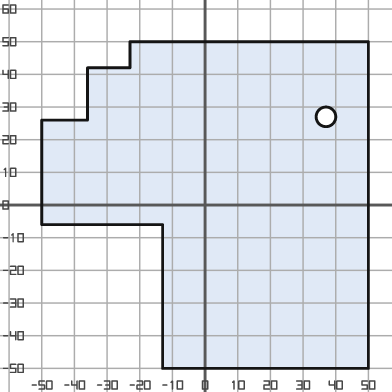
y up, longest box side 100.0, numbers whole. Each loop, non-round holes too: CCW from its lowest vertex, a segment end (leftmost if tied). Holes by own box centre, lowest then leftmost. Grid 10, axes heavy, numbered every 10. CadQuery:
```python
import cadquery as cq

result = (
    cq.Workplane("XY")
    .moveTo(-13.0, -50.0)
    .lineTo(50.0, -50.0)
    .lineTo(50.0, 50.0)
    .lineTo(-23.0, 50.0)
    .lineTo(-23.0, 42.0)
    .lineTo(-36.0, 42.0)
    .lineTo(-36.0, 26.0)
    .lineTo(-50.0, 26.0)
    .lineTo(-50.0, -6.0)
    .lineTo(-13.0, -6.0)
    .close()
    .moveTo(37.0, 27.0)
    .circle(3.0)
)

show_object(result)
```